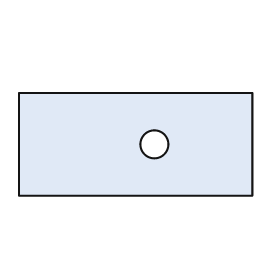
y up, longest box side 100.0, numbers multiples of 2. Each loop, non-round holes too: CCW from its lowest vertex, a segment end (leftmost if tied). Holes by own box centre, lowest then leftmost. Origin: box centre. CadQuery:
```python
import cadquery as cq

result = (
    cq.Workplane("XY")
    .moveTo(-50.0, -22.0)
    .lineTo(50.0, -22.0)
    .lineTo(50.0, 22.0)
    .lineTo(-50.0, 22.0)
    .close()
    .moveTo(8.0, 0.0)
    .circle(6.0)
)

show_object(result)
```